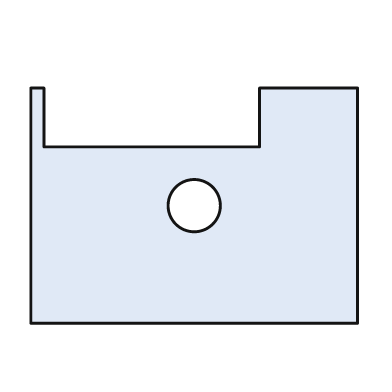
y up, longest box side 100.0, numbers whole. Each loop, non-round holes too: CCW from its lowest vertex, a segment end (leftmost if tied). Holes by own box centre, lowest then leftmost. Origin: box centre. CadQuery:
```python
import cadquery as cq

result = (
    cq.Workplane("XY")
    .moveTo(-50.0, -36.0)
    .lineTo(50.0, -36.0)
    .lineTo(50.0, 36.0)
    .lineTo(20.0, 36.0)
    .lineTo(20.0, 18.0)
    .lineTo(-46.0, 18.0)
    .lineTo(-46.0, 36.0)
    .lineTo(-50.0, 36.0)
    .close()
    .moveTo(0.0, 0.0)
    .circle(8.0)
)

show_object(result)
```